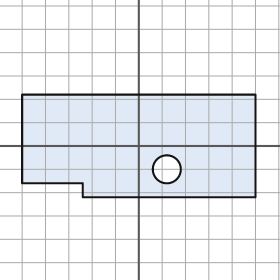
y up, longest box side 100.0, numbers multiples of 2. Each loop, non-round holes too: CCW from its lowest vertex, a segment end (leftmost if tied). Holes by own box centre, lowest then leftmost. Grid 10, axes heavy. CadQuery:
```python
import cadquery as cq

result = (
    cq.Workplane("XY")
    .moveTo(-24.0, -22.0)
    .lineTo(50.0, -22.0)
    .lineTo(50.0, 22.0)
    .lineTo(-50.0, 22.0)
    .lineTo(-50.0, -16.0)
    .lineTo(-24.0, -16.0)
    .close()
    .moveTo(12.0, -10.0)
    .circle(6.0)
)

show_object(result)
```